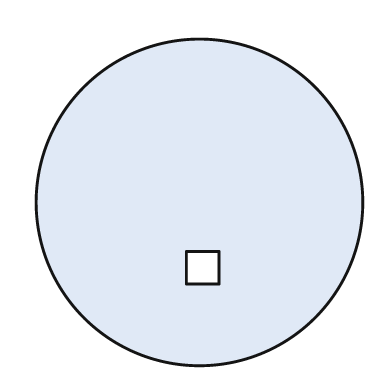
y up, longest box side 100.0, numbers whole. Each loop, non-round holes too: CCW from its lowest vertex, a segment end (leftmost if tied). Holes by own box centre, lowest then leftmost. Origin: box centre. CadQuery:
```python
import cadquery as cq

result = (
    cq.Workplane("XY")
    .moveTo(0.0, 0.0)
    .circle(50.0)
    .moveTo(-4.0, -25.0)
    .lineTo(6.0, -25.0)
    .lineTo(6.0, -15.0)
    .lineTo(-4.0, -15.0)
    .close()
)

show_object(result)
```